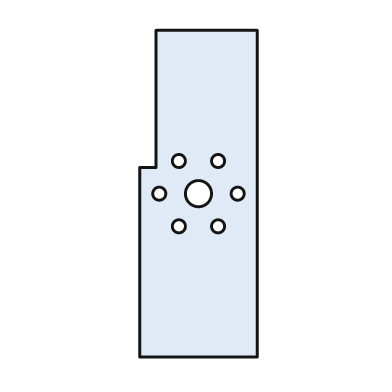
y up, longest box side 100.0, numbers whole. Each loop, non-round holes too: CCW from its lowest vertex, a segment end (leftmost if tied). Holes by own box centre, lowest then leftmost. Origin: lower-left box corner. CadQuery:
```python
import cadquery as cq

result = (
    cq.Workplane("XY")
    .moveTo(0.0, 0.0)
    .lineTo(36.0, 0.0)
    .lineTo(36.0, 100.0)
    .lineTo(5.0, 100.0)
    .lineTo(5.0, 58.0)
    .lineTo(0.0, 58.0)
    .close()
    .moveTo(12.0, 40.0)
    .circle(2.0)
    .moveTo(24.0, 40.0)
    .circle(2.0)
    .moveTo(6.0, 50.0)
    .circle(2.0)
    .moveTo(18.0, 50.0)
    .circle(4.0)
    .moveTo(30.0, 50.0)
    .circle(2.0)
    .moveTo(12.0, 60.0)
    .circle(2.0)
    .moveTo(24.0, 60.0)
    .circle(2.0)
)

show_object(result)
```